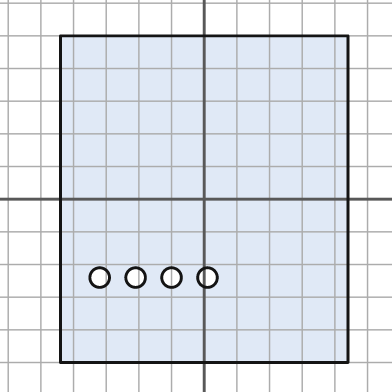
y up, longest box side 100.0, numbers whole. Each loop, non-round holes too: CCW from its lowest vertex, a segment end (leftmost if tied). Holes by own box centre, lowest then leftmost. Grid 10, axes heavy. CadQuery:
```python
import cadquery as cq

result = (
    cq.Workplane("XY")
    .moveTo(-44.0, -50.0)
    .lineTo(44.0, -50.0)
    .lineTo(44.0, 50.0)
    .lineTo(-44.0, 50.0)
    .close()
    .moveTo(-32.0, -24.0)
    .circle(3.0)
    .moveTo(-21.0, -24.0)
    .circle(3.0)
    .moveTo(-10.0, -24.0)
    .circle(3.0)
    .moveTo(1.0, -24.0)
    .circle(3.0)
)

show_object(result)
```